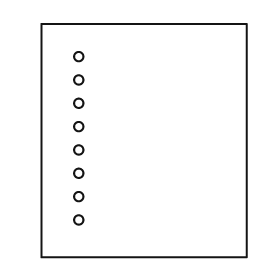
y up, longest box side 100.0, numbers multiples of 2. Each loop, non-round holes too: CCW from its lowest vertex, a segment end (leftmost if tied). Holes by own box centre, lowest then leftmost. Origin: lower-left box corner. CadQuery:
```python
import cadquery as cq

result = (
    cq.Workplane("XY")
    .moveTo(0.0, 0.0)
    .lineTo(88.0, 0.0)
    .lineTo(88.0, 100.0)
    .lineTo(0.0, 100.0)
    .close()
    .moveTo(16.0, 16.0)
    .circle(2.0)
    .moveTo(16.0, 26.0)
    .circle(2.0)
    .moveTo(16.0, 36.0)
    .circle(2.0)
    .moveTo(16.0, 46.0)
    .circle(2.0)
    .moveTo(16.0, 56.0)
    .circle(2.0)
    .moveTo(16.0, 66.0)
    .circle(2.0)
    .moveTo(16.0, 76.0)
    .circle(2.0)
    .moveTo(16.0, 86.0)
    .circle(2.0)
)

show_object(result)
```